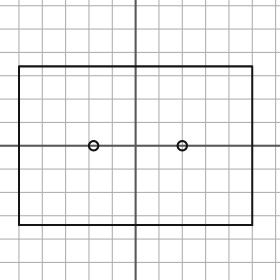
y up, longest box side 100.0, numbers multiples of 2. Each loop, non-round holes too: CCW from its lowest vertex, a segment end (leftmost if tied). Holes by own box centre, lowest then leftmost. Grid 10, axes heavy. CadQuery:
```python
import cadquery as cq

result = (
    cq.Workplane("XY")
    .moveTo(-50.0, -34.0)
    .lineTo(50.0, -34.0)
    .lineTo(50.0, 34.0)
    .lineTo(-50.0, 34.0)
    .close()
    .moveTo(-18.0, 0.0)
    .circle(2.0)
    .moveTo(20.0, 0.0)
    .circle(2.0)
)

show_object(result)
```